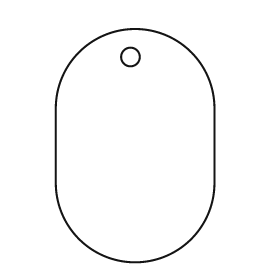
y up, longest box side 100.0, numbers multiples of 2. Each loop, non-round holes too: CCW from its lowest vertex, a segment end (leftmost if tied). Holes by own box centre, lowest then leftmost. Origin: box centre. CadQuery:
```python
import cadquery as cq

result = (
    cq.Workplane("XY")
    .moveTo(-34.0, -16.0)
    .threePointArc((0.0, -50.0), (34.0, -16.0))
    .lineTo(34.0, 16.0)
    .threePointArc((0.0, 50.0), (-34.0, 16.0))
    .close()
    .moveTo(-2.0, 38.0)
    .circle(4.0)
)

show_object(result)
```